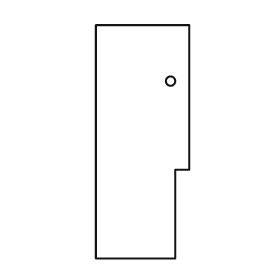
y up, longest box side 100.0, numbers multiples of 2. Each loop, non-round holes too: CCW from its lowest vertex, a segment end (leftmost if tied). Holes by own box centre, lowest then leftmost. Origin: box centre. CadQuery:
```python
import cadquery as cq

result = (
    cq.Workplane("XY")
    .moveTo(-20.0, -50.0)
    .lineTo(14.0, -50.0)
    .lineTo(14.0, -12.0)
    .lineTo(20.0, -12.0)
    .lineTo(20.0, 50.0)
    .lineTo(-20.0, 50.0)
    .close()
    .moveTo(12.0, 26.0)
    .circle(2.0)
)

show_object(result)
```